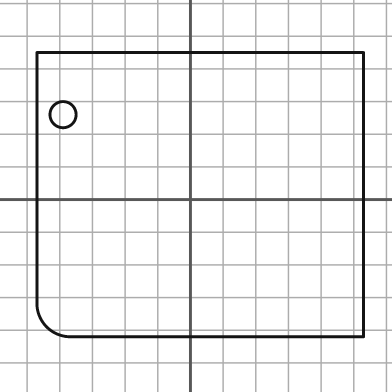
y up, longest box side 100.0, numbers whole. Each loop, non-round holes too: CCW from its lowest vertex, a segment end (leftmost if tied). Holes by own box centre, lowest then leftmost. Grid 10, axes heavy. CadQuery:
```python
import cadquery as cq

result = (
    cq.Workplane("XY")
    .moveTo(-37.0, -42.0)
    .lineTo(53.0, -42.0)
    .lineTo(53.0, 45.0)
    .lineTo(-47.0, 45.0)
    .lineTo(-47.0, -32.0)
    .threePointArc((-44.0, -39.0), (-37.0, -42.0))
    .close()
    .moveTo(-39.0, 26.0)
    .circle(4.0)
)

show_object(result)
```